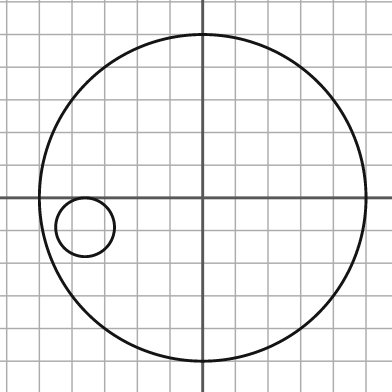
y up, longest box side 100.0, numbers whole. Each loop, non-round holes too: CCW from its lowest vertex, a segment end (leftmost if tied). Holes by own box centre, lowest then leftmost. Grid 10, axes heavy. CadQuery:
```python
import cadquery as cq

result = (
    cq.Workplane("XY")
    .moveTo(0.0, 0.0)
    .circle(50.0)
    .moveTo(-36.0, -9.0)
    .circle(9.0)
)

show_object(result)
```